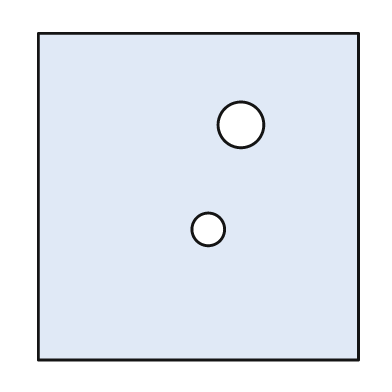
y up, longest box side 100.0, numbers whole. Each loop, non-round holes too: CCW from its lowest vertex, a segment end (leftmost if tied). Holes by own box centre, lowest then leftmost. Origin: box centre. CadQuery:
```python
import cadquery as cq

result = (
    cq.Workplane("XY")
    .moveTo(-49.0, -50.0)
    .lineTo(49.0, -50.0)
    .lineTo(49.0, 50.0)
    .lineTo(-49.0, 50.0)
    .close()
    .moveTo(3.0, -10.0)
    .circle(5.0)
    .moveTo(13.0, 22.0)
    .circle(7.0)
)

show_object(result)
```